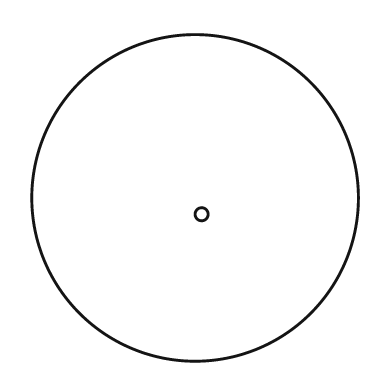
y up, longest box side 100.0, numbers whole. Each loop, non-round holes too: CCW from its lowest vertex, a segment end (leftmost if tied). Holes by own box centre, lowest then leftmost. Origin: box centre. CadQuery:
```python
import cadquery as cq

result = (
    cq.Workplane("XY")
    .moveTo(0.0, 0.0)
    .circle(50.0)
    .moveTo(2.0, -5.0)
    .circle(2.0)
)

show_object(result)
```